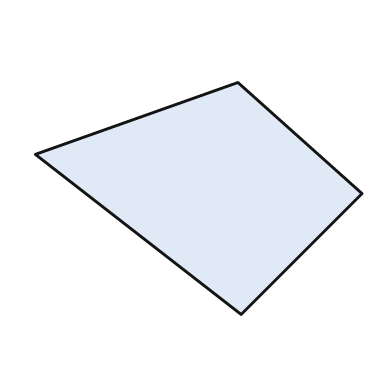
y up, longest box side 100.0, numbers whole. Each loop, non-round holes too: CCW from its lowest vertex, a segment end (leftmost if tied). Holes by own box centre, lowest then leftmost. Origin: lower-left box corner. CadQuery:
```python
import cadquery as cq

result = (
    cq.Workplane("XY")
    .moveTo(63.0, 0.0)
    .lineTo(100.0, 37.0)
    .lineTo(62.0, 71.0)
    .lineTo(0.0, 49.0)
    .close()
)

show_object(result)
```